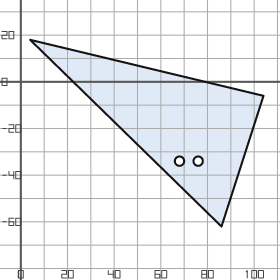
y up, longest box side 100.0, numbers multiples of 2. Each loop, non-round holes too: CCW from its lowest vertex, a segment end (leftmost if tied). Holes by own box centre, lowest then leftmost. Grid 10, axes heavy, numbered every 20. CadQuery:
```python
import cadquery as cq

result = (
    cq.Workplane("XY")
    .moveTo(86.0, -62.0)
    .lineTo(104.0, -6.0)
    .lineTo(4.0, 18.0)
    .close()
    .moveTo(68.0, -34.0)
    .circle(2.0)
    .moveTo(76.0, -34.0)
    .circle(2.0)
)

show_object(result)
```